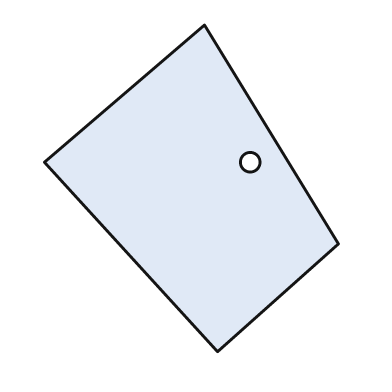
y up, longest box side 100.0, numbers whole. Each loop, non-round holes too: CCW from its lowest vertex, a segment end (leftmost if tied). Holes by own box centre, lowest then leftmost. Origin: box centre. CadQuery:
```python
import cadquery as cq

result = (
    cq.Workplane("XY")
    .moveTo(8.0, -50.0)
    .lineTo(45.0, -17.0)
    .lineTo(4.0, 50.0)
    .lineTo(-45.0, 8.0)
    .close()
    .moveTo(18.0, 8.0)
    .circle(3.0)
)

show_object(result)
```